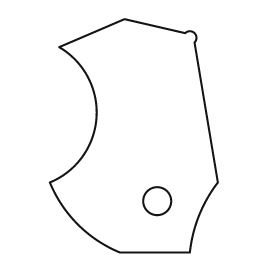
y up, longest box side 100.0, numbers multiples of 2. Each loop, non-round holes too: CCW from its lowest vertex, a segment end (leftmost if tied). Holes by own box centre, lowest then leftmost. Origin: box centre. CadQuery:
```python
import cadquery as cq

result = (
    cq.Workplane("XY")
    .moveTo(-6.0, -50.0)
    .lineTo(24.0, -50.0)
    .threePointArc((28.0, -34.0), (36.0, -20.0))
    .lineTo(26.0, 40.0)
    .threePointArc((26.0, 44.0), (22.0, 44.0))
    .lineTo(-4.0, 50.0)
    .lineTo(-32.0, 38.0)
    .threePointArc((-16.0, 8.0), (-36.0, -20.0))
    .threePointArc((-24.0, -38.0), (-6.0, -50.0))
    .close()
    .moveTo(10.0, -28.0)
    .circle(6.0)
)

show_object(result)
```